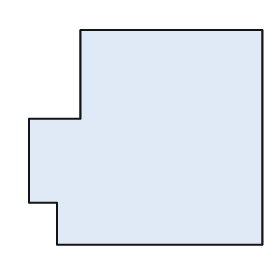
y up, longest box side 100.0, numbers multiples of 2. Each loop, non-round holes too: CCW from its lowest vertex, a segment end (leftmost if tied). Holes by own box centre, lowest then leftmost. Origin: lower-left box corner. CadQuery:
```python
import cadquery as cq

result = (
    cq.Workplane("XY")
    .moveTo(12.0, 0.0)
    .lineTo(100.0, 0.0)
    .lineTo(100.0, 92.0)
    .lineTo(22.0, 92.0)
    .lineTo(22.0, 54.0)
    .lineTo(0.0, 54.0)
    .lineTo(0.0, 18.0)
    .lineTo(12.0, 18.0)
    .close()
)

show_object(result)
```